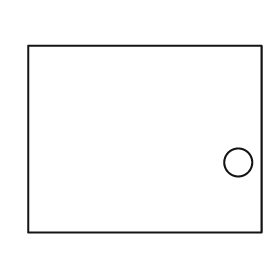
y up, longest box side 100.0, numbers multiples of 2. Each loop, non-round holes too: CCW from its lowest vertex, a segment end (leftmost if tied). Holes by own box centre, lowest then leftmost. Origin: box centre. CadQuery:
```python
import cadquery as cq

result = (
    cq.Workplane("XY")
    .moveTo(-50.0, -40.0)
    .lineTo(50.0, -40.0)
    .lineTo(50.0, 40.0)
    .lineTo(-50.0, 40.0)
    .close()
    .moveTo(40.0, -10.0)
    .circle(6.0)
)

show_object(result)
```